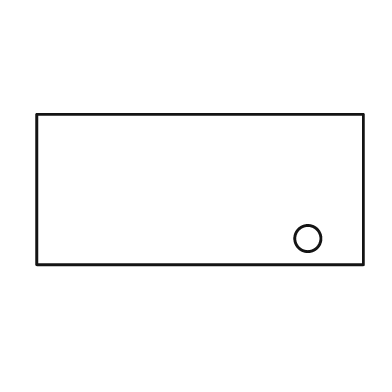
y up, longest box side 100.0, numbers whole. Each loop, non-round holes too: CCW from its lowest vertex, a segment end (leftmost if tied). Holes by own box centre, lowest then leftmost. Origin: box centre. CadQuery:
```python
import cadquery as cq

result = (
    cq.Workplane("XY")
    .moveTo(-50.0, -23.0)
    .lineTo(50.0, -23.0)
    .lineTo(50.0, 23.0)
    .lineTo(-50.0, 23.0)
    .close()
    .moveTo(33.0, -15.0)
    .circle(4.0)
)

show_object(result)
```